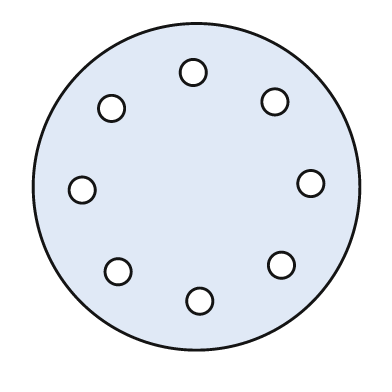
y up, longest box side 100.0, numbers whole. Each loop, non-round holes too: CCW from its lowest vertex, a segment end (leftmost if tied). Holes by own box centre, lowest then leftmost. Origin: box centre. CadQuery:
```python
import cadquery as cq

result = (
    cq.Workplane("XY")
    .moveTo(0.0, 0.0)
    .circle(50.0)
    .moveTo(1.0, -35.0)
    .circle(4.0)
    .moveTo(-24.0, -26.0)
    .circle(4.0)
    .moveTo(26.0, -24.0)
    .circle(4.0)
    .moveTo(-35.0, -1.0)
    .circle(4.0)
    .moveTo(35.0, 1.0)
    .circle(4.0)
    .moveTo(-26.0, 24.0)
    .circle(4.0)
    .moveTo(24.0, 26.0)
    .circle(4.0)
    .moveTo(-1.0, 35.0)
    .circle(4.0)
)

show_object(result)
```